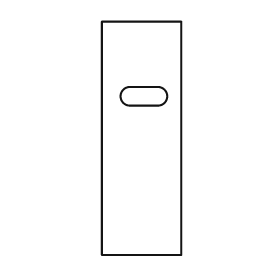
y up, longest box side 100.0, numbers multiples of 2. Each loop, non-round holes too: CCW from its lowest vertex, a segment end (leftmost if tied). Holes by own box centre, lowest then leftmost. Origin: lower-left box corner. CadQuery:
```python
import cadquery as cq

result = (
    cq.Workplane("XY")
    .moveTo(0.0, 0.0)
    .lineTo(34.0, 0.0)
    .lineTo(34.0, 100.0)
    .lineTo(0.0, 100.0)
    .close()
    .moveTo(12.0, 64.0)
    .lineTo(24.0, 64.0)
    .threePointArc((28.0, 68.0), (24.0, 72.0))
    .lineTo(12.0, 72.0)
    .threePointArc((8.0, 68.0), (12.0, 64.0))
    .close()
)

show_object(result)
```